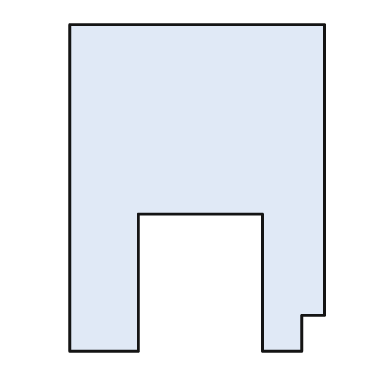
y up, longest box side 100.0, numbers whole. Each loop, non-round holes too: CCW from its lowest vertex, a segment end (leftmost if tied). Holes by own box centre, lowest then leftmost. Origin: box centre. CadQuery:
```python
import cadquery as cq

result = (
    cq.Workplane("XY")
    .moveTo(-39.0, -50.0)
    .lineTo(-18.0, -50.0)
    .lineTo(-18.0, -8.0)
    .lineTo(20.0, -8.0)
    .lineTo(20.0, -50.0)
    .lineTo(32.0, -50.0)
    .lineTo(32.0, -39.0)
    .lineTo(39.0, -39.0)
    .lineTo(39.0, 50.0)
    .lineTo(-39.0, 50.0)
    .close()
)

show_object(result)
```